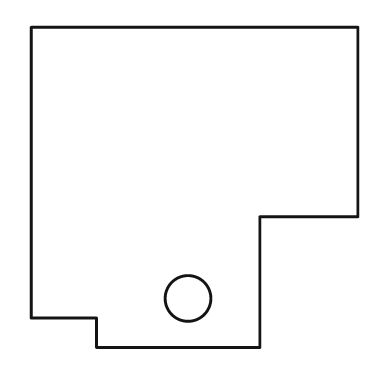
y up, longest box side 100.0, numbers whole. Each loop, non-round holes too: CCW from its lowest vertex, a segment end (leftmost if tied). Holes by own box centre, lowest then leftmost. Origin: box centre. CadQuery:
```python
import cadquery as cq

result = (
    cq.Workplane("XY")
    .moveTo(-30.0, -49.0)
    .lineTo(20.0, -49.0)
    .lineTo(20.0, -9.0)
    .lineTo(50.0, -9.0)
    .lineTo(50.0, 49.0)
    .lineTo(-50.0, 49.0)
    .lineTo(-50.0, -40.0)
    .lineTo(-30.0, -40.0)
    .close()
    .moveTo(-2.0, -34.0)
    .circle(7.0)
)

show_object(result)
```